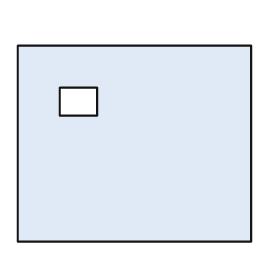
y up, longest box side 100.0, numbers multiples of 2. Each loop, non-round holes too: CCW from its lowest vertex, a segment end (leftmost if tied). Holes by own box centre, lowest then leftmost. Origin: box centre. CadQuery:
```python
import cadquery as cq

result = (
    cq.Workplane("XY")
    .moveTo(-50.0, -42.0)
    .lineTo(50.0, -42.0)
    .lineTo(50.0, 42.0)
    .lineTo(-50.0, 42.0)
    .close()
    .moveTo(-32.0, 12.0)
    .lineTo(-16.0, 12.0)
    .lineTo(-16.0, 24.0)
    .lineTo(-32.0, 24.0)
    .close()
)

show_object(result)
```